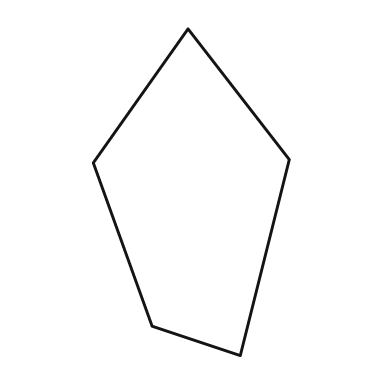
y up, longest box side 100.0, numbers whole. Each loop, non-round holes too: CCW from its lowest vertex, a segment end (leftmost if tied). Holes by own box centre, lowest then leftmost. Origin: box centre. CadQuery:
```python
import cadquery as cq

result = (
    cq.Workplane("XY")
    .moveTo(15.0, -50.0)
    .lineTo(30.0, 10.0)
    .lineTo(-1.0, 50.0)
    .lineTo(-30.0, 9.0)
    .lineTo(-12.0, -41.0)
    .close()
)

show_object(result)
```